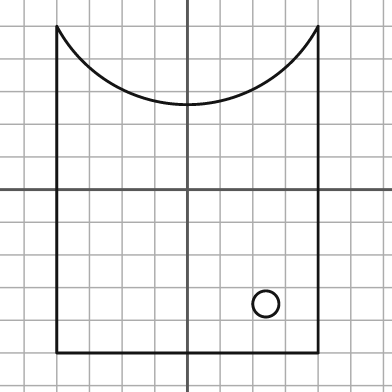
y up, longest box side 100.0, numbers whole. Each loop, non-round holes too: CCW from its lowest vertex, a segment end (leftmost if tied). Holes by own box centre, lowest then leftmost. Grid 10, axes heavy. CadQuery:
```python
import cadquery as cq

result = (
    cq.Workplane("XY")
    .moveTo(-40.0, -50.0)
    .lineTo(40.0, -50.0)
    .lineTo(40.0, 50.0)
    .threePointArc((0.0, 26.0), (-40.0, 50.0))
    .close()
    .moveTo(24.0, -35.0)
    .circle(4.0)
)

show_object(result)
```